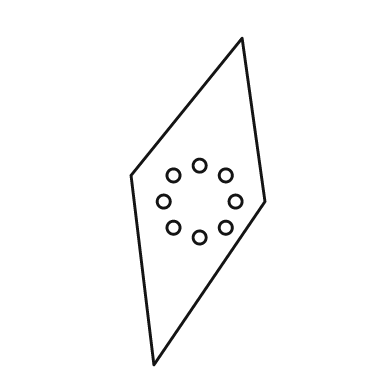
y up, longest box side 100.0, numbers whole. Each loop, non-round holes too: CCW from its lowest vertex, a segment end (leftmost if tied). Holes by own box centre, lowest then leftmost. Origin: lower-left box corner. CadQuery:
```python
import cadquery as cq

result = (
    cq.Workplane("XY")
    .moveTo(7.0, 0.0)
    .lineTo(41.0, 50.0)
    .lineTo(34.0, 100.0)
    .lineTo(0.0, 58.0)
    .close()
    .moveTo(21.0, 39.0)
    .circle(2.0)
    .moveTo(13.0, 42.0)
    .circle(2.0)
    .moveTo(29.0, 42.0)
    .circle(2.0)
    .moveTo(10.0, 50.0)
    .circle(2.0)
    .moveTo(32.0, 50.0)
    .circle(2.0)
    .moveTo(13.0, 58.0)
    .circle(2.0)
    .moveTo(29.0, 58.0)
    .circle(2.0)
    .moveTo(21.0, 61.0)
    .circle(2.0)
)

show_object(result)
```